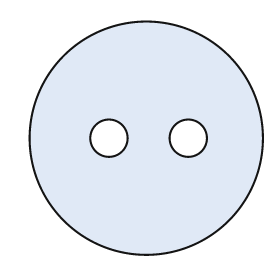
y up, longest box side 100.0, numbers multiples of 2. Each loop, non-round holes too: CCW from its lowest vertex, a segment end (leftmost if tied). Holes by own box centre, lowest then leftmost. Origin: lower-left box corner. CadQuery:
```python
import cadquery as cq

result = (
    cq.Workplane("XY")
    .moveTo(50.0, 50.0)
    .circle(50.0)
    .moveTo(34.0, 50.0)
    .circle(8.0)
    .moveTo(68.0, 50.0)
    .circle(8.0)
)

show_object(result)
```